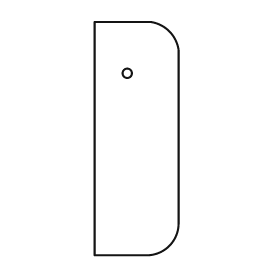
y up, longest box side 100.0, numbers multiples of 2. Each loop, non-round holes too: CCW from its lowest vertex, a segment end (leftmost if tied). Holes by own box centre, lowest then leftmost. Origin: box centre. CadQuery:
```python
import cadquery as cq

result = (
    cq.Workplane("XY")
    .moveTo(-18.0, -50.0)
    .lineTo(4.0, -50.0)
    .threePointArc((14.0, -46.0), (18.0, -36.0))
    .lineTo(18.0, 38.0)
    .threePointArc((14.0, 46.0), (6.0, 50.0))
    .lineTo(-18.0, 50.0)
    .close()
    .moveTo(-4.0, 28.0)
    .circle(2.0)
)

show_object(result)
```